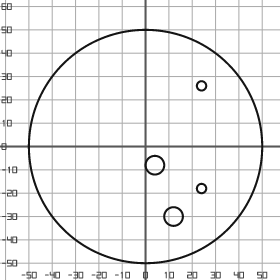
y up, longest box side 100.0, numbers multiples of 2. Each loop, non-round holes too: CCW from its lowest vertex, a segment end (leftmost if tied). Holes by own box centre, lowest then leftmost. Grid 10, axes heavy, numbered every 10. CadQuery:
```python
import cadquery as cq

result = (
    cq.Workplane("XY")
    .moveTo(0.0, 0.0)
    .circle(50.0)
    .moveTo(12.0, -30.0)
    .circle(4.0)
    .moveTo(24.0, -18.0)
    .circle(2.0)
    .moveTo(4.0, -8.0)
    .circle(4.0)
    .moveTo(24.0, 26.0)
    .circle(2.0)
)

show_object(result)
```